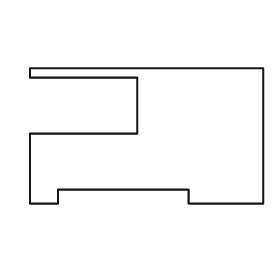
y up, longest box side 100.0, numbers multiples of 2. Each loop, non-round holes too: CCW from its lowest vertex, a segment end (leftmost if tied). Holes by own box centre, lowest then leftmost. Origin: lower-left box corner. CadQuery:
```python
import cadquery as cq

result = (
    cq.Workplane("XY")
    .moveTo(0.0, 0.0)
    .lineTo(12.0, 0.0)
    .lineTo(12.0, 6.0)
    .lineTo(68.0, 6.0)
    .lineTo(68.0, 0.0)
    .lineTo(100.0, 0.0)
    .lineTo(100.0, 58.0)
    .lineTo(0.0, 58.0)
    .lineTo(0.0, 54.0)
    .lineTo(46.0, 54.0)
    .lineTo(46.0, 30.0)
    .lineTo(0.0, 30.0)
    .close()
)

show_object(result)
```